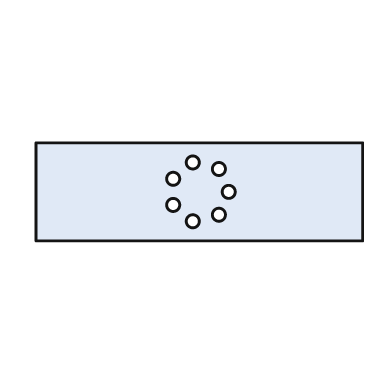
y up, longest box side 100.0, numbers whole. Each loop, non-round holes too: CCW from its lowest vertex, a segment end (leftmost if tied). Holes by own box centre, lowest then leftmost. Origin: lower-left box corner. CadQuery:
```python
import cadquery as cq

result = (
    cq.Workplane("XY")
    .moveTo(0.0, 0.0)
    .lineTo(100.0, 0.0)
    .lineTo(100.0, 30.0)
    .lineTo(0.0, 30.0)
    .close()
    .moveTo(48.0, 6.0)
    .circle(2.0)
    .moveTo(56.0, 8.0)
    .circle(2.0)
    .moveTo(42.0, 11.0)
    .circle(2.0)
    .moveTo(59.0, 15.0)
    .circle(2.0)
    .moveTo(42.0, 19.0)
    .circle(2.0)
    .moveTo(56.0, 22.0)
    .circle(2.0)
    .moveTo(48.0, 24.0)
    .circle(2.0)
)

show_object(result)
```